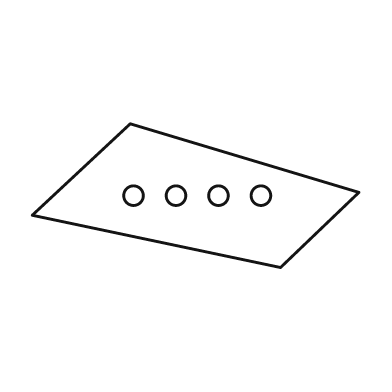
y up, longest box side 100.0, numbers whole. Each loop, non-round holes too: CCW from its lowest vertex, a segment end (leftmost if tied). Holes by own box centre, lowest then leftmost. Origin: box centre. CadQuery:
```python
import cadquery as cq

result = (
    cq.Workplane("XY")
    .moveTo(26.0, -22.0)
    .lineTo(50.0, 1.0)
    .lineTo(-20.0, 22.0)
    .lineTo(-50.0, -6.0)
    .close()
    .moveTo(-19.0, 0.0)
    .circle(3.0)
    .moveTo(-6.0, 0.0)
    .circle(3.0)
    .moveTo(7.0, 0.0)
    .circle(3.0)
    .moveTo(20.0, 0.0)
    .circle(3.0)
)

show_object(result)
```